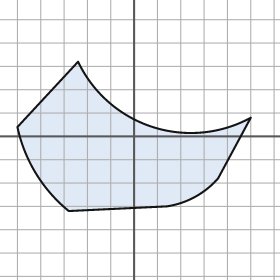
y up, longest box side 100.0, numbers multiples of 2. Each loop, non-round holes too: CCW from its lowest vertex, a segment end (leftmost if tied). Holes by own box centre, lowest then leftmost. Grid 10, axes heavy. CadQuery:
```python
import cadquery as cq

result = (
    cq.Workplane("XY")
    .moveTo(-28.0, -32.0)
    .lineTo(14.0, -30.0)
    .threePointArc((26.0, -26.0), (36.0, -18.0))
    .lineTo(50.0, 8.0)
    .threePointArc((8.0, 4.0), (-24.0, 32.0))
    .lineTo(-50.0, 4.0)
    .threePointArc((-42.0, -16.0), (-28.0, -32.0))
    .close()
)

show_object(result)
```